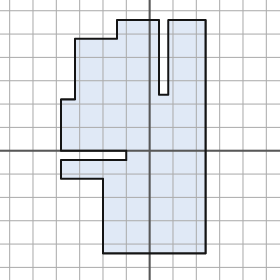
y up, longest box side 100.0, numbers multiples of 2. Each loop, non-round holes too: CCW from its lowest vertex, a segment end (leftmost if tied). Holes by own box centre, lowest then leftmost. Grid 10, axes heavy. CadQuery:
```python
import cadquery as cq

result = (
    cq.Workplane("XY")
    .moveTo(-20.0, -44.0)
    .lineTo(24.0, -44.0)
    .lineTo(24.0, 56.0)
    .lineTo(8.0, 56.0)
    .lineTo(8.0, 24.0)
    .lineTo(4.0, 24.0)
    .lineTo(4.0, 56.0)
    .lineTo(-14.0, 56.0)
    .lineTo(-14.0, 48.0)
    .lineTo(-32.0, 48.0)
    .lineTo(-32.0, 22.0)
    .lineTo(-38.0, 22.0)
    .lineTo(-38.0, 0.0)
    .lineTo(-10.0, 0.0)
    .lineTo(-10.0, -4.0)
    .lineTo(-38.0, -4.0)
    .lineTo(-38.0, -12.0)
    .lineTo(-20.0, -12.0)
    .close()
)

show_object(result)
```